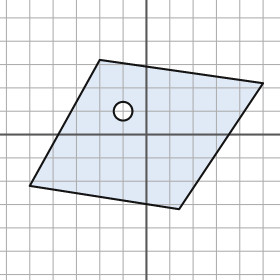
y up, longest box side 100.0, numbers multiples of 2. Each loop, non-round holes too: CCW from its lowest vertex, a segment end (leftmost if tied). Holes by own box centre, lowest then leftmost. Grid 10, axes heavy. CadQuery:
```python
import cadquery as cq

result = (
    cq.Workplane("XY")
    .moveTo(14.0, -32.0)
    .lineTo(50.0, 22.0)
    .lineTo(-20.0, 32.0)
    .lineTo(-50.0, -22.0)
    .close()
    .moveTo(-10.0, 10.0)
    .circle(4.0)
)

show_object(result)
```